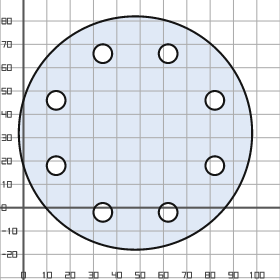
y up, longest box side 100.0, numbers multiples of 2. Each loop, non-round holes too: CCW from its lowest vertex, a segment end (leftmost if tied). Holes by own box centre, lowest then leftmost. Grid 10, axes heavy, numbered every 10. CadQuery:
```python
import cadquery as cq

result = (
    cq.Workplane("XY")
    .moveTo(48.0, 32.0)
    .circle(50.0)
    .moveTo(34.0, -2.0)
    .circle(4.0)
    .moveTo(62.0, -2.0)
    .circle(4.0)
    .moveTo(14.0, 18.0)
    .circle(4.0)
    .moveTo(82.0, 18.0)
    .circle(4.0)
    .moveTo(14.0, 46.0)
    .circle(4.0)
    .moveTo(82.0, 46.0)
    .circle(4.0)
    .moveTo(34.0, 66.0)
    .circle(4.0)
    .moveTo(62.0, 66.0)
    .circle(4.0)
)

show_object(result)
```